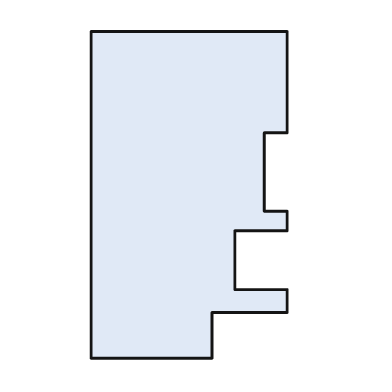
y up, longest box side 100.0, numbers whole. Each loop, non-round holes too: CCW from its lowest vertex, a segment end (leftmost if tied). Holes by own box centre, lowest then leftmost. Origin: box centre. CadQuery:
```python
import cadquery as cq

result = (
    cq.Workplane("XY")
    .moveTo(-30.0, -50.0)
    .lineTo(7.0, -50.0)
    .lineTo(7.0, -36.0)
    .lineTo(30.0, -36.0)
    .lineTo(30.0, -29.0)
    .lineTo(14.0, -29.0)
    .lineTo(14.0, -11.0)
    .lineTo(30.0, -11.0)
    .lineTo(30.0, -5.0)
    .lineTo(23.0, -5.0)
    .lineTo(23.0, 19.0)
    .lineTo(30.0, 19.0)
    .lineTo(30.0, 50.0)
    .lineTo(-30.0, 50.0)
    .close()
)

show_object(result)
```